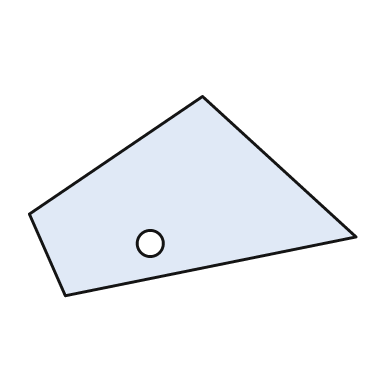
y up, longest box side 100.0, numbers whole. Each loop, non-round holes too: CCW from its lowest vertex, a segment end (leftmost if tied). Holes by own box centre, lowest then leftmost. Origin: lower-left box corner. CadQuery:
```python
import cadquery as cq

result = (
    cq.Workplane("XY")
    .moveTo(11.0, 0.0)
    .lineTo(100.0, 18.0)
    .lineTo(53.0, 61.0)
    .lineTo(0.0, 25.0)
    .close()
    .moveTo(37.0, 16.0)
    .circle(4.0)
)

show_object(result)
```